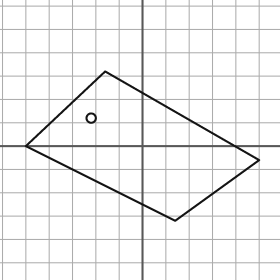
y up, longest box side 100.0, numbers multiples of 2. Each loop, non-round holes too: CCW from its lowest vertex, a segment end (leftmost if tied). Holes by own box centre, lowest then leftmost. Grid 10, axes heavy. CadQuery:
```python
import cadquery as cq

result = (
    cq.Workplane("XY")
    .moveTo(14.0, -32.0)
    .lineTo(50.0, -6.0)
    .lineTo(-16.0, 32.0)
    .lineTo(-50.0, 0.0)
    .close()
    .moveTo(-22.0, 12.0)
    .circle(2.0)
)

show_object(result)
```